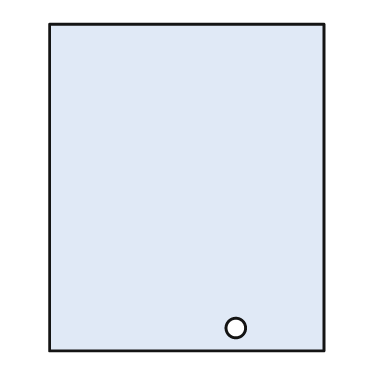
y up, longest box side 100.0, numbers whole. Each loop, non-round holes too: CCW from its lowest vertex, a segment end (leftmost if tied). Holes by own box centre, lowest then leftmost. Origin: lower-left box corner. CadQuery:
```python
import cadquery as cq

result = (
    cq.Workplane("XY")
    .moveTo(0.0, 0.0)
    .lineTo(84.0, 0.0)
    .lineTo(84.0, 100.0)
    .lineTo(0.0, 100.0)
    .close()
    .moveTo(57.0, 7.0)
    .circle(3.0)
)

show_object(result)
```